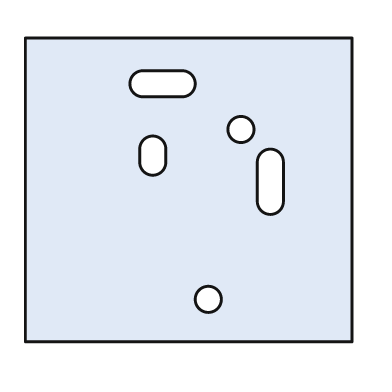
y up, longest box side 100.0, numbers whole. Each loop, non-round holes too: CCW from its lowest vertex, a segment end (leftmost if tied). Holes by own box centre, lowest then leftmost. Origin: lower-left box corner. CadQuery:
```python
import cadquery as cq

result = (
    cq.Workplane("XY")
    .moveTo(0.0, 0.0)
    .lineTo(100.0, 0.0)
    .lineTo(100.0, 93.0)
    .lineTo(0.0, 93.0)
    .close()
    .moveTo(56.0, 13.0)
    .circle(4.0)
    .moveTo(71.0, 43.0)
    .threePointArc((75.0, 39.0), (79.0, 43.0))
    .lineTo(79.0, 55.0)
    .threePointArc((75.0, 59.0), (71.0, 55.0))
    .close()
    .moveTo(35.0, 55.0)
    .threePointArc((39.0, 51.0), (43.0, 55.0))
    .lineTo(43.0, 59.0)
    .threePointArc((39.0, 63.0), (35.0, 59.0))
    .close()
    .moveTo(66.0, 65.0)
    .circle(4.0)
    .moveTo(36.0, 75.0)
    .lineTo(48.0, 75.0)
    .threePointArc((52.0, 79.0), (48.0, 83.0))
    .lineTo(36.0, 83.0)
    .threePointArc((32.0, 79.0), (36.0, 75.0))
    .close()
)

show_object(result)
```